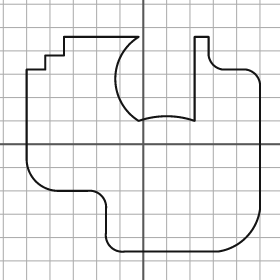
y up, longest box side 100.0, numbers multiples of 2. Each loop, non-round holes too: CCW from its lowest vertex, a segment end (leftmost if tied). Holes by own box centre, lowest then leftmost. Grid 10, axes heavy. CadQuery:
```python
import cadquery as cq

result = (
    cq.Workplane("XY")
    .moveTo(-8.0, -46.0)
    .lineTo(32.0, -46.0)
    .threePointArc((44.0, -40.0), (50.0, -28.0))
    .lineTo(50.0, 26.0)
    .threePointArc((48.0, 30.0), (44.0, 32.0))
    .lineTo(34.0, 32.0)
    .threePointArc((30.0, 34.0), (28.0, 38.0))
    .lineTo(28.0, 46.0)
    .lineTo(22.0, 46.0)
    .lineTo(22.0, 10.0)
    .threePointArc((10.0, 12.0), (-2.0, 10.0))
    .threePointArc((-12.0, 28.0), (-2.0, 46.0))
    .lineTo(-34.0, 46.0)
    .lineTo(-34.0, 38.0)
    .lineTo(-42.0, 38.0)
    .lineTo(-42.0, 32.0)
    .lineTo(-50.0, 32.0)
    .lineTo(-50.0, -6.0)
    .threePointArc((-46.0, -16.0), (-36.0, -20.0))
    .lineTo(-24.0, -20.0)
    .threePointArc((-18.0, -22.0), (-16.0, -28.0))
    .lineTo(-16.0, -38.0)
    .threePointArc((-14.0, -44.0), (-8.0, -46.0))
    .close()
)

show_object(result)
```